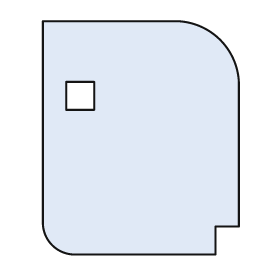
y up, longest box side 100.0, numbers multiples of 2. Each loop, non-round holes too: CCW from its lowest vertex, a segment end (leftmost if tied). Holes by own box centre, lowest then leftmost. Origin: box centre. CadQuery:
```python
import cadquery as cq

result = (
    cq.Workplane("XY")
    .moveTo(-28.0, -50.0)
    .lineTo(32.0, -50.0)
    .lineTo(32.0, -38.0)
    .lineTo(42.0, -38.0)
    .lineTo(42.0, 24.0)
    .threePointArc((34.0, 42.0), (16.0, 50.0))
    .lineTo(-42.0, 50.0)
    .lineTo(-42.0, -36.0)
    .threePointArc((-38.0, -46.0), (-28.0, -50.0))
    .close()
    .moveTo(-32.0, 12.0)
    .lineTo(-20.0, 12.0)
    .lineTo(-20.0, 24.0)
    .lineTo(-32.0, 24.0)
    .close()
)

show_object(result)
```